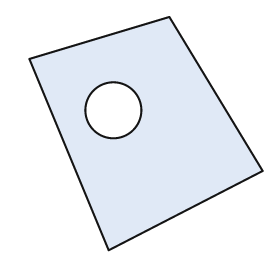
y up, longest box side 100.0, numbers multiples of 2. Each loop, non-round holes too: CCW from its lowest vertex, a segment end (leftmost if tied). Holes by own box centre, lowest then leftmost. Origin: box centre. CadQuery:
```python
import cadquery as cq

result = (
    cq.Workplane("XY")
    .moveTo(-16.0, -50.0)
    .lineTo(50.0, -16.0)
    .lineTo(10.0, 50.0)
    .lineTo(-50.0, 32.0)
    .close()
    .moveTo(-14.0, 10.0)
    .circle(12.0)
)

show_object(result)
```